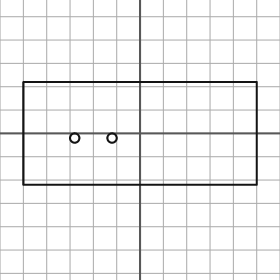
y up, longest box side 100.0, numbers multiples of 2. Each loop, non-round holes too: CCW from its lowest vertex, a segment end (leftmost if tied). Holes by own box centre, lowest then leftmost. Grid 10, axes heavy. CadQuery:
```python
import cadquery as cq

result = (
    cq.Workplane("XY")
    .moveTo(-50.0, -22.0)
    .lineTo(50.0, -22.0)
    .lineTo(50.0, 22.0)
    .lineTo(-50.0, 22.0)
    .close()
    .moveTo(-28.0, -2.0)
    .circle(2.0)
    .moveTo(-12.0, -2.0)
    .circle(2.0)
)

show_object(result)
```